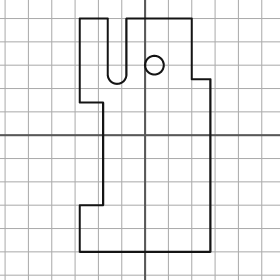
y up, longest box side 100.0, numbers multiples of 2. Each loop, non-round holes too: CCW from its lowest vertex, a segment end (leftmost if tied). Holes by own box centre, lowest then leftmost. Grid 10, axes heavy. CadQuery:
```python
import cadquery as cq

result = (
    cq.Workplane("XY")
    .moveTo(-28.0, -50.0)
    .lineTo(28.0, -50.0)
    .lineTo(28.0, 24.0)
    .lineTo(20.0, 24.0)
    .lineTo(20.0, 50.0)
    .lineTo(-8.0, 50.0)
    .lineTo(-8.0, 26.0)
    .threePointArc((-12.0, 22.0), (-16.0, 26.0))
    .lineTo(-16.0, 50.0)
    .lineTo(-28.0, 50.0)
    .lineTo(-28.0, 14.0)
    .lineTo(-18.0, 14.0)
    .lineTo(-18.0, -30.0)
    .lineTo(-28.0, -30.0)
    .close()
    .moveTo(4.0, 30.0)
    .circle(4.0)
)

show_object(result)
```